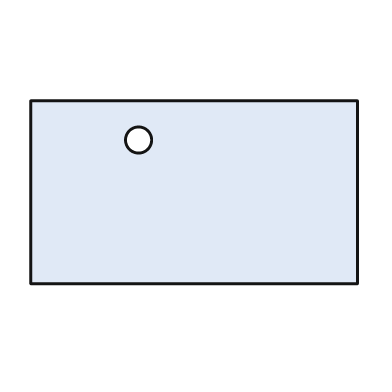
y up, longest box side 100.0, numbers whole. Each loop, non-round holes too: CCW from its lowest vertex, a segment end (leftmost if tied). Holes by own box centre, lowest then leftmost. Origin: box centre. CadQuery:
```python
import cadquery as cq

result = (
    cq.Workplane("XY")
    .moveTo(-50.0, -28.0)
    .lineTo(50.0, -28.0)
    .lineTo(50.0, 28.0)
    .lineTo(-50.0, 28.0)
    .close()
    .moveTo(-17.0, 16.0)
    .circle(4.0)
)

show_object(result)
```